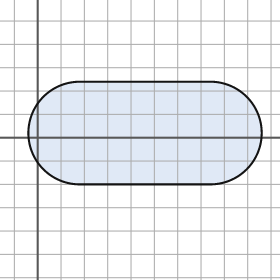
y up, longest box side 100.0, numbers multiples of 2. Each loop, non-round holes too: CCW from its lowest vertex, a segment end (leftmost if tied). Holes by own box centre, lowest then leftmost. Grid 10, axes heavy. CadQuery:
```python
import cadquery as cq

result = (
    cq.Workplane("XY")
    .moveTo(18.0, -20.0)
    .lineTo(74.0, -20.0)
    .threePointArc((96.0, 2.0), (74.0, 24.0))
    .lineTo(18.0, 24.0)
    .threePointArc((-4.0, 2.0), (18.0, -20.0))
    .close()
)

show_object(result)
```